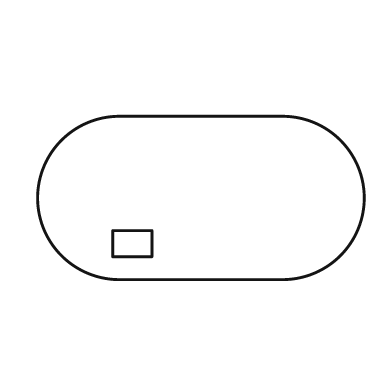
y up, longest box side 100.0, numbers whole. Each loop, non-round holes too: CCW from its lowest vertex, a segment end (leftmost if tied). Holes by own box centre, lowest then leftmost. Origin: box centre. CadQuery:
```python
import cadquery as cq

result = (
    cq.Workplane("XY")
    .moveTo(-25.0, -25.0)
    .lineTo(25.0, -25.0)
    .threePointArc((50.0, 0.0), (25.0, 25.0))
    .lineTo(-25.0, 25.0)
    .threePointArc((-50.0, 0.0), (-25.0, -25.0))
    .close()
    .moveTo(-27.0, -18.0)
    .lineTo(-15.0, -18.0)
    .lineTo(-15.0, -10.0)
    .lineTo(-27.0, -10.0)
    .close()
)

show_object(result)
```